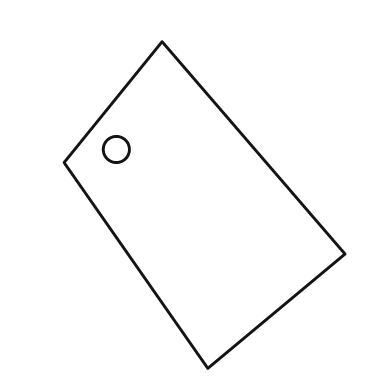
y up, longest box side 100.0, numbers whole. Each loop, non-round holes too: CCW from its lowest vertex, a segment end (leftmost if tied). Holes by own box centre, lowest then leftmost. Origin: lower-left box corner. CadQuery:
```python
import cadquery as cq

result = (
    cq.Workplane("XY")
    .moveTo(44.0, 0.0)
    .lineTo(86.0, 35.0)
    .lineTo(30.0, 100.0)
    .lineTo(0.0, 63.0)
    .close()
    .moveTo(16.0, 67.0)
    .circle(4.0)
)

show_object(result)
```